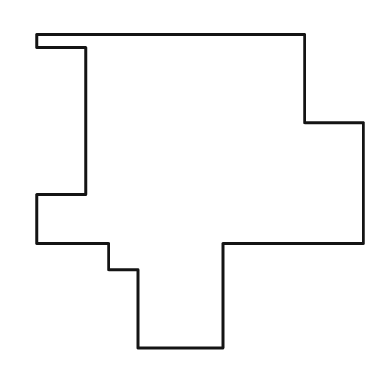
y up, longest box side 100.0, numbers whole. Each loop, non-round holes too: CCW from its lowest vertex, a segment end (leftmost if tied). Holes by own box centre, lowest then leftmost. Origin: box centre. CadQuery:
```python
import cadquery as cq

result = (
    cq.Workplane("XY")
    .moveTo(-19.0, -48.0)
    .lineTo(7.0, -48.0)
    .lineTo(7.0, -16.0)
    .lineTo(50.0, -16.0)
    .lineTo(50.0, 21.0)
    .lineTo(32.0, 21.0)
    .lineTo(32.0, 48.0)
    .lineTo(-50.0, 48.0)
    .lineTo(-50.0, 44.0)
    .lineTo(-35.0, 44.0)
    .lineTo(-35.0, -1.0)
    .lineTo(-50.0, -1.0)
    .lineTo(-50.0, -16.0)
    .lineTo(-28.0, -16.0)
    .lineTo(-28.0, -24.0)
    .lineTo(-19.0, -24.0)
    .close()
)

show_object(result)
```